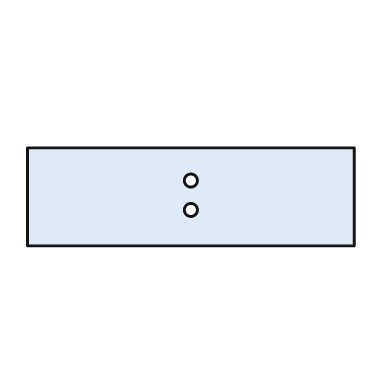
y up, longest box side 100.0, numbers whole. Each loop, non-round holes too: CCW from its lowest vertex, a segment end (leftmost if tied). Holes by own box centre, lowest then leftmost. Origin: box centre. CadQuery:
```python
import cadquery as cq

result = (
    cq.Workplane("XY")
    .moveTo(-50.0, -15.0)
    .lineTo(50.0, -15.0)
    .lineTo(50.0, 15.0)
    .lineTo(-50.0, 15.0)
    .close()
    .moveTo(0.0, -4.0)
    .circle(2.0)
    .moveTo(0.0, 5.0)
    .circle(2.0)
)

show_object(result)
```